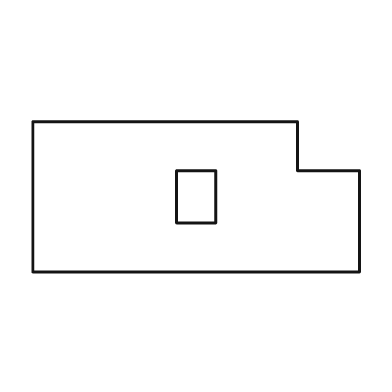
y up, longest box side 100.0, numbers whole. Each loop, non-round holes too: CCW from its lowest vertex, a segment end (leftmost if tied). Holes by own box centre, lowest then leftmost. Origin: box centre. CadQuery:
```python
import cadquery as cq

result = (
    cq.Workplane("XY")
    .moveTo(-50.0, -23.0)
    .lineTo(50.0, -23.0)
    .lineTo(50.0, 8.0)
    .lineTo(31.0, 8.0)
    .lineTo(31.0, 23.0)
    .lineTo(-50.0, 23.0)
    .close()
    .moveTo(-6.0, -8.0)
    .lineTo(6.0, -8.0)
    .lineTo(6.0, 8.0)
    .lineTo(-6.0, 8.0)
    .close()
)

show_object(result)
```